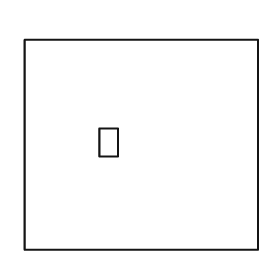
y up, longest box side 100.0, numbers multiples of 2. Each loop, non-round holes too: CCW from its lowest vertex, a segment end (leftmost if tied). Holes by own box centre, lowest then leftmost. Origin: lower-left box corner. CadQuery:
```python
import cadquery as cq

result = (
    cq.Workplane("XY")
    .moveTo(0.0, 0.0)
    .lineTo(100.0, 0.0)
    .lineTo(100.0, 90.0)
    .lineTo(0.0, 90.0)
    .close()
    .moveTo(32.0, 40.0)
    .lineTo(40.0, 40.0)
    .lineTo(40.0, 52.0)
    .lineTo(32.0, 52.0)
    .close()
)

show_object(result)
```